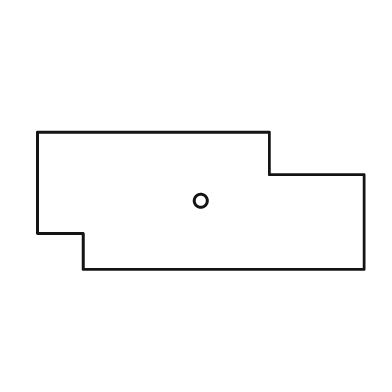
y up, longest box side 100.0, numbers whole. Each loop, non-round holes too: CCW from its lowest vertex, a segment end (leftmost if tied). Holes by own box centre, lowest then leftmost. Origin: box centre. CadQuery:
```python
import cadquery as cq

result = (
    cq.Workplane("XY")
    .moveTo(-36.0, -21.0)
    .lineTo(50.0, -21.0)
    .lineTo(50.0, 8.0)
    .lineTo(21.0, 8.0)
    .lineTo(21.0, 21.0)
    .lineTo(-50.0, 21.0)
    .lineTo(-50.0, -10.0)
    .lineTo(-36.0, -10.0)
    .close()
    .moveTo(0.0, 0.0)
    .circle(2.0)
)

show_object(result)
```